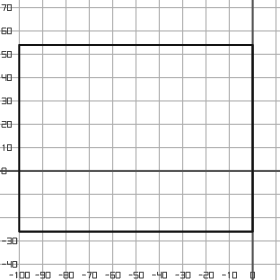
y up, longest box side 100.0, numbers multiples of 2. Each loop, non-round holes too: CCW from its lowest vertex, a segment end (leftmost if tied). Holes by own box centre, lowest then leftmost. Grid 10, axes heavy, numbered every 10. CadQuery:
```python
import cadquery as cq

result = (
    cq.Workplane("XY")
    .moveTo(-100.0, -26.0)
    .lineTo(0.0, -26.0)
    .lineTo(0.0, 54.0)
    .lineTo(-100.0, 54.0)
    .close()
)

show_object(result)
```